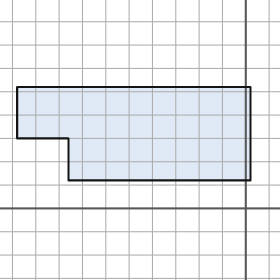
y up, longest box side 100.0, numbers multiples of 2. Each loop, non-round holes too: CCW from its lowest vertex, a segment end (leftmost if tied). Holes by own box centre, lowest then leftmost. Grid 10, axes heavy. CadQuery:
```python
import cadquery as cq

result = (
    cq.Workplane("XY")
    .moveTo(-76.0, 12.0)
    .lineTo(2.0, 12.0)
    .lineTo(2.0, 52.0)
    .lineTo(-98.0, 52.0)
    .lineTo(-98.0, 30.0)
    .lineTo(-76.0, 30.0)
    .close()
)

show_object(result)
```